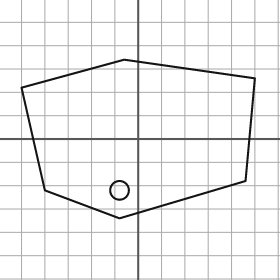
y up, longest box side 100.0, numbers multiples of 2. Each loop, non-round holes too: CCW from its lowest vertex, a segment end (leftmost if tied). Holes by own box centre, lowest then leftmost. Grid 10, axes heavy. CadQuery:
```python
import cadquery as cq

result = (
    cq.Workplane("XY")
    .moveTo(-8.0, -34.0)
    .lineTo(46.0, -18.0)
    .lineTo(50.0, 26.0)
    .lineTo(-6.0, 34.0)
    .lineTo(-50.0, 22.0)
    .lineTo(-40.0, -22.0)
    .close()
    .moveTo(-8.0, -22.0)
    .circle(4.0)
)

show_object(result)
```